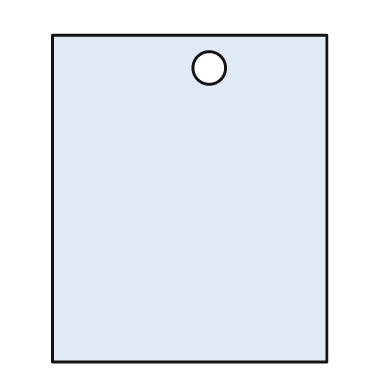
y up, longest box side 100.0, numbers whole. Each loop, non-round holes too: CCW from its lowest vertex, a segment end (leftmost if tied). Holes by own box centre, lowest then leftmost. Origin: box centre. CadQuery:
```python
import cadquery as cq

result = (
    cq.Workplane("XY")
    .moveTo(-42.0, -50.0)
    .lineTo(42.0, -50.0)
    .lineTo(42.0, 50.0)
    .lineTo(-42.0, 50.0)
    .close()
    .moveTo(6.0, 40.0)
    .circle(5.0)
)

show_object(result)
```